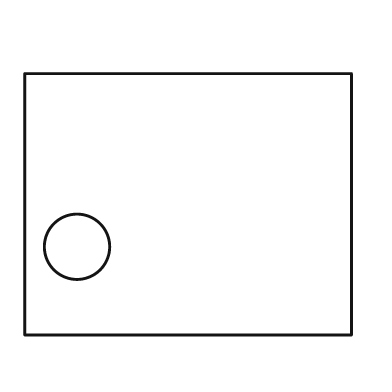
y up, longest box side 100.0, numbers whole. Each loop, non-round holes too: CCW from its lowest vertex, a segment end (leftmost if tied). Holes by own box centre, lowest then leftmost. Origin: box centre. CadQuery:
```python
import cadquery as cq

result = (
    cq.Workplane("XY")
    .moveTo(-50.0, -40.0)
    .lineTo(50.0, -40.0)
    .lineTo(50.0, 40.0)
    .lineTo(-50.0, 40.0)
    .close()
    .moveTo(-34.0, -13.0)
    .circle(10.0)
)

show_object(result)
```